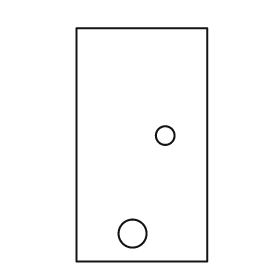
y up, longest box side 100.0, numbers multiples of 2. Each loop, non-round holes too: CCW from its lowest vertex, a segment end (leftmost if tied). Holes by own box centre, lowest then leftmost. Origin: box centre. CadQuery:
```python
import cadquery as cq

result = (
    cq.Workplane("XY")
    .moveTo(-28.0, -50.0)
    .lineTo(28.0, -50.0)
    .lineTo(28.0, 50.0)
    .lineTo(-28.0, 50.0)
    .close()
    .moveTo(-4.0, -38.0)
    .circle(6.0)
    .moveTo(10.0, 4.0)
    .circle(4.0)
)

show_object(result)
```